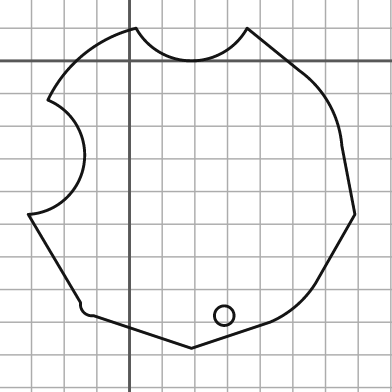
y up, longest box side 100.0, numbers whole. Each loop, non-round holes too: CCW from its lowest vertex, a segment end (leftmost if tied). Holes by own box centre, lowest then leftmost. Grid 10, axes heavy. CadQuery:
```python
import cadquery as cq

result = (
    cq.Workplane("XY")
    .moveTo(19.0, -88.0)
    .lineTo(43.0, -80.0)
    .threePointArc((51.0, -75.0), (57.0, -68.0))
    .lineTo(69.0, -47.0)
    .lineTo(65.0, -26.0)
    .threePointArc((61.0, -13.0), (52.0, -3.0))
    .lineTo(36.0, 10.0)
    .threePointArc((19.0, 0.0), (2.0, 10.0))
    .threePointArc((-14.0, 2.0), (-25.0, -12.0))
    .threePointArc((-14.0, -32.0), (-31.0, -47.0))
    .lineTo(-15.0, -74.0)
    .threePointArc((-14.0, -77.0), (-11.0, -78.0))
    .close()
    .moveTo(29.0, -78.0)
    .circle(3.0)
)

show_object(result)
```